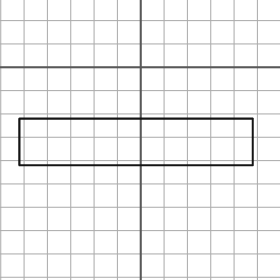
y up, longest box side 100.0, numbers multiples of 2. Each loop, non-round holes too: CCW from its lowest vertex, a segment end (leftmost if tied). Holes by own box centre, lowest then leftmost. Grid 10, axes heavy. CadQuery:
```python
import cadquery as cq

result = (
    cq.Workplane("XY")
    .moveTo(-52.0, -42.0)
    .lineTo(48.0, -42.0)
    .lineTo(48.0, -22.0)
    .lineTo(-52.0, -22.0)
    .close()
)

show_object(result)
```